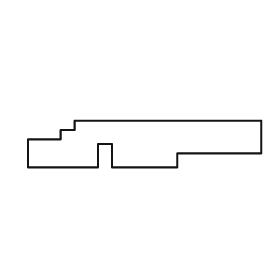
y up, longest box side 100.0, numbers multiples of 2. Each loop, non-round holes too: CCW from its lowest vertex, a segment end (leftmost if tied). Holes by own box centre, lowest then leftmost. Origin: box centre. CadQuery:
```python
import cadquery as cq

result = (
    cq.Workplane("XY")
    .moveTo(-50.0, -10.0)
    .lineTo(-20.0, -10.0)
    .lineTo(-20.0, 0.0)
    .lineTo(-14.0, 0.0)
    .lineTo(-14.0, -10.0)
    .lineTo(14.0, -10.0)
    .lineTo(14.0, -4.0)
    .lineTo(50.0, -4.0)
    .lineTo(50.0, 10.0)
    .lineTo(-30.0, 10.0)
    .lineTo(-30.0, 6.0)
    .lineTo(-36.0, 6.0)
    .lineTo(-36.0, 2.0)
    .lineTo(-50.0, 2.0)
    .close()
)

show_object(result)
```